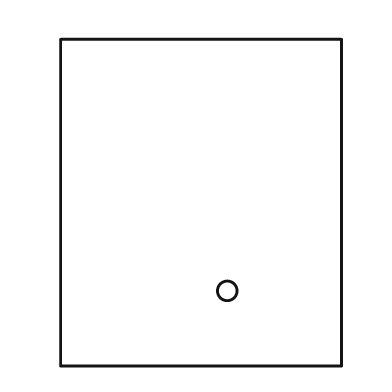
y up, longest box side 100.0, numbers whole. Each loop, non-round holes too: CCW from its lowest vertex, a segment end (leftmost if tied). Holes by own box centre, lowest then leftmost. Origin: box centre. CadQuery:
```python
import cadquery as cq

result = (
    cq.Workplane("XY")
    .moveTo(-43.0, -50.0)
    .lineTo(43.0, -50.0)
    .lineTo(43.0, 50.0)
    .lineTo(-43.0, 50.0)
    .close()
    .moveTo(8.0, -27.0)
    .circle(3.0)
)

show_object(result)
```